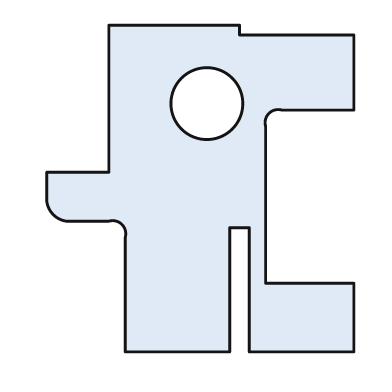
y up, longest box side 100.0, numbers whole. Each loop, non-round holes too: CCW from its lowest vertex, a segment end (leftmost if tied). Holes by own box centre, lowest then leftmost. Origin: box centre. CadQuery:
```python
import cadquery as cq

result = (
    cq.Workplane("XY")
    .moveTo(-23.0, -50.0)
    .lineTo(9.0, -50.0)
    .lineTo(9.0, -12.0)
    .lineTo(15.0, -12.0)
    .lineTo(15.0, -50.0)
    .lineTo(47.0, -50.0)
    .lineTo(47.0, -29.0)
    .lineTo(20.0, -29.0)
    .lineTo(20.0, 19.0)
    .threePointArc((21.0, 23.0), (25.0, 24.0))
    .lineTo(47.0, 24.0)
    .lineTo(47.0, 47.0)
    .lineTo(12.0, 47.0)
    .lineTo(12.0, 50.0)
    .lineTo(-28.0, 50.0)
    .lineTo(-28.0, 5.0)
    .lineTo(-47.0, 5.0)
    .lineTo(-47.0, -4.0)
    .threePointArc((-45.0, -8.0), (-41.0, -10.0))
    .lineTo(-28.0, -10.0)
    .threePointArc((-24.0, -11.0), (-23.0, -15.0))
    .close()
    .moveTo(2.0, 26.0)
    .circle(11.0)
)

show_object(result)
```